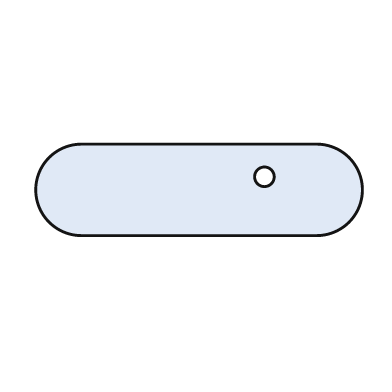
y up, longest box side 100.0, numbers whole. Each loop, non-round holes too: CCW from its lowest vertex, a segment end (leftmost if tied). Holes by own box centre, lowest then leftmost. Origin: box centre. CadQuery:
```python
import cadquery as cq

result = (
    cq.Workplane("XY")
    .moveTo(-36.0, -14.0)
    .lineTo(36.0, -14.0)
    .threePointArc((50.0, 0.0), (36.0, 14.0))
    .lineTo(-36.0, 14.0)
    .threePointArc((-50.0, 0.0), (-36.0, -14.0))
    .close()
    .moveTo(20.0, 4.0)
    .circle(3.0)
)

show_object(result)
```